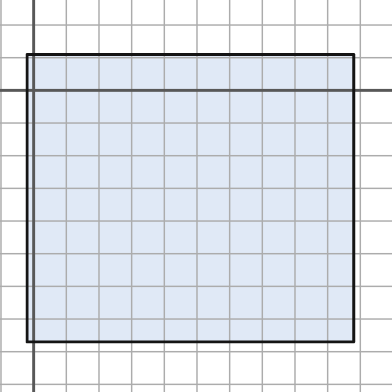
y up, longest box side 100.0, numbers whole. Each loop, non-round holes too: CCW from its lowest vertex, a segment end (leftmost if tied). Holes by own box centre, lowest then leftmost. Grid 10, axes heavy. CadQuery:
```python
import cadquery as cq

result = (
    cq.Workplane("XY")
    .moveTo(-2.0, -77.0)
    .lineTo(98.0, -77.0)
    .lineTo(98.0, 11.0)
    .lineTo(-2.0, 11.0)
    .close()
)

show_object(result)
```